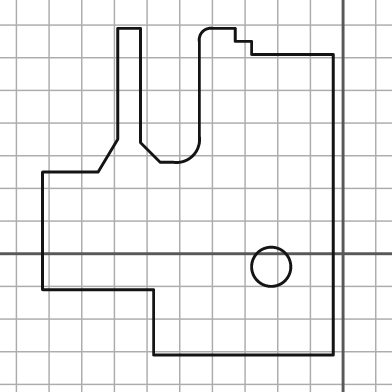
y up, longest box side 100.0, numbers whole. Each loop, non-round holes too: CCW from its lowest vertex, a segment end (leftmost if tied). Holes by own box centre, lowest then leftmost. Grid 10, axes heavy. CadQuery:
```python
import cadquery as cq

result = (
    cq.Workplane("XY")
    .moveTo(-58.0, -31.0)
    .lineTo(-3.0, -31.0)
    .lineTo(-3.0, 61.0)
    .lineTo(-28.0, 61.0)
    .lineTo(-28.0, 65.0)
    .lineTo(-33.0, 65.0)
    .lineTo(-33.0, 69.0)
    .lineTo(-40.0, 69.0)
    .threePointArc((-43.0, 68.0), (-44.0, 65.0))
    .lineTo(-44.0, 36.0)
    .threePointArc((-46.0, 30.0), (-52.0, 28.0))
    .lineTo(-56.0, 28.0)
    .lineTo(-62.0, 34.0)
    .lineTo(-62.0, 69.0)
    .lineTo(-69.0, 69.0)
    .lineTo(-69.0, 35.0)
    .lineTo(-75.0, 25.0)
    .lineTo(-92.0, 25.0)
    .lineTo(-92.0, -11.0)
    .lineTo(-58.0, -11.0)
    .close()
    .moveTo(-22.0, -4.0)
    .circle(6.0)
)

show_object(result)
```